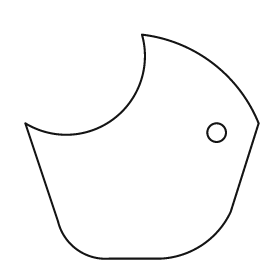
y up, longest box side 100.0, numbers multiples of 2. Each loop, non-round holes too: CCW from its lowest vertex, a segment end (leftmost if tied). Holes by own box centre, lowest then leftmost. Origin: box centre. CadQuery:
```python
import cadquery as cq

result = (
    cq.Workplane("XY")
    .moveTo(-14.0, -48.0)
    .lineTo(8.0, -48.0)
    .threePointArc((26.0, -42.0), (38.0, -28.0))
    .lineTo(50.0, 10.0)
    .threePointArc((30.0, 36.0), (0.0, 48.0))
    .threePointArc((-12.0, 12.0), (-50.0, 10.0))
    .lineTo(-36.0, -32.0)
    .threePointArc((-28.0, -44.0), (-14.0, -48.0))
    .close()
    .moveTo(32.0, 6.0)
    .circle(4.0)
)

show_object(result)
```